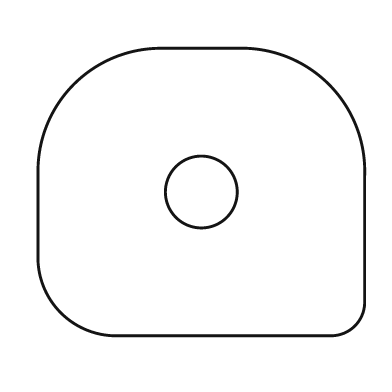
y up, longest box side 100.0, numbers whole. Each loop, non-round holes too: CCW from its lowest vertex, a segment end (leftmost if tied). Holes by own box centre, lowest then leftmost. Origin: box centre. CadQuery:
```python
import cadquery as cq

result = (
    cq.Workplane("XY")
    .moveTo(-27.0, -44.0)
    .lineTo(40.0, -44.0)
    .threePointArc((47.0, -41.0), (50.0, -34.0))
    .lineTo(50.0, 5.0)
    .threePointArc((39.0, 33.0), (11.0, 44.0))
    .lineTo(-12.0, 44.0)
    .threePointArc((-39.0, 33.0), (-50.0, 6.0))
    .lineTo(-50.0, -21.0)
    .threePointArc((-43.0, -37.0), (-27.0, -44.0))
    .close()
    .moveTo(0.0, 0.0)
    .circle(11.0)
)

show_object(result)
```